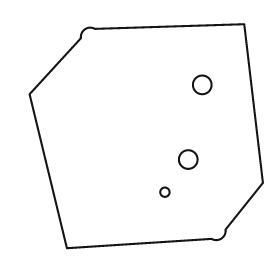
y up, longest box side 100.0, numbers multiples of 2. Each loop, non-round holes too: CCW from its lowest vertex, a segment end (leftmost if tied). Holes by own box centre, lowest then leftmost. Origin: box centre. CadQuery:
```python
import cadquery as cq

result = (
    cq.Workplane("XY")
    .moveTo(-34.0, -48.0)
    .lineTo(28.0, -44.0)
    .threePointArc((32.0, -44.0), (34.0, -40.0))
    .lineTo(50.0, -20.0)
    .lineTo(42.0, 48.0)
    .lineTo(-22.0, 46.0)
    .threePointArc((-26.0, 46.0), (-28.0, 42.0))
    .lineTo(-50.0, 18.0)
    .close()
    .moveTo(8.0, -24.0)
    .circle(2.0)
    .moveTo(18.0, -10.0)
    .circle(4.0)
    .moveTo(24.0, 22.0)
    .circle(4.0)
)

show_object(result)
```